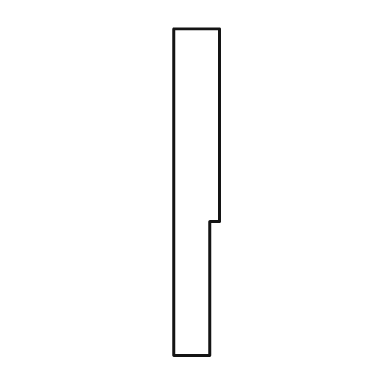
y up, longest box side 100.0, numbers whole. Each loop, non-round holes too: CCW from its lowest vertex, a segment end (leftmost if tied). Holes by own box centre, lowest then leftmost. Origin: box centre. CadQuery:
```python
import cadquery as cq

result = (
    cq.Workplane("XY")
    .moveTo(-7.0, -50.0)
    .lineTo(4.0, -50.0)
    .lineTo(4.0, -9.0)
    .lineTo(7.0, -9.0)
    .lineTo(7.0, 50.0)
    .lineTo(-7.0, 50.0)
    .close()
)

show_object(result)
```